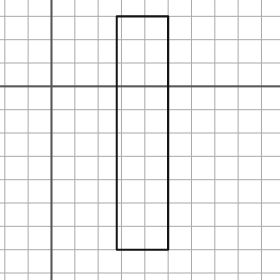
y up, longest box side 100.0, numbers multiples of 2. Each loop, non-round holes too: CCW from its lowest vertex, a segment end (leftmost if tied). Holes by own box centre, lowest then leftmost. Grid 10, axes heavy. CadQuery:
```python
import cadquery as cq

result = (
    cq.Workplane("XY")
    .moveTo(28.0, -70.0)
    .lineTo(50.0, -70.0)
    .lineTo(50.0, 30.0)
    .lineTo(28.0, 30.0)
    .close()
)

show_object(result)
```